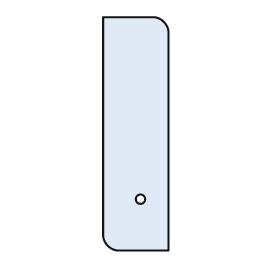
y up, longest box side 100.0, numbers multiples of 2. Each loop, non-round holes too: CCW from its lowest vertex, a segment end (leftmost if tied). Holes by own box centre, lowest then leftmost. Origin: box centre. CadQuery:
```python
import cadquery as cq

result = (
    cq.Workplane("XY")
    .moveTo(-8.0, -50.0)
    .lineTo(14.0, -50.0)
    .lineTo(14.0, 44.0)
    .threePointArc((12.0, 48.0), (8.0, 50.0))
    .lineTo(-14.0, 50.0)
    .lineTo(-14.0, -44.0)
    .threePointArc((-12.0, -48.0), (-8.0, -50.0))
    .close()
    .moveTo(2.0, -28.0)
    .circle(2.0)
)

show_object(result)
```